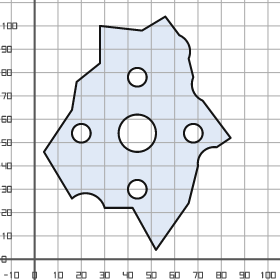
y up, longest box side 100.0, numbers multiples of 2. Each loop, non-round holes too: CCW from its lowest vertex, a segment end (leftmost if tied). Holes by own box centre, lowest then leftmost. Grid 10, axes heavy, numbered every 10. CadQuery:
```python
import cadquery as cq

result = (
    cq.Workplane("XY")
    .moveTo(52.0, 4.0)
    .lineTo(66.0, 24.0)
    .lineTo(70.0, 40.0)
    .threePointArc((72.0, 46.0), (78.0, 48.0))
    .lineTo(84.0, 52.0)
    .lineTo(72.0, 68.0)
    .threePointArc((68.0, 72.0), (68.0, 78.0))
    .lineTo(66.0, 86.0)
    .threePointArc((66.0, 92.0), (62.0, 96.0))
    .lineTo(56.0, 104.0)
    .lineTo(46.0, 98.0)
    .lineTo(28.0, 100.0)
    .lineTo(28.0, 84.0)
    .lineTo(18.0, 76.0)
    .lineTo(16.0, 64.0)
    .lineTo(4.0, 46.0)
    .lineTo(16.0, 26.0)
    .threePointArc((24.0, 28.0), (30.0, 22.0))
    .lineTo(42.0, 22.0)
    .close()
    .moveTo(44.0, 30.0)
    .circle(4.0)
    .moveTo(20.0, 54.0)
    .circle(4.0)
    .moveTo(44.0, 54.0)
    .circle(8.0)
    .moveTo(68.0, 54.0)
    .circle(4.0)
    .moveTo(44.0, 78.0)
    .circle(4.0)
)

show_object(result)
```